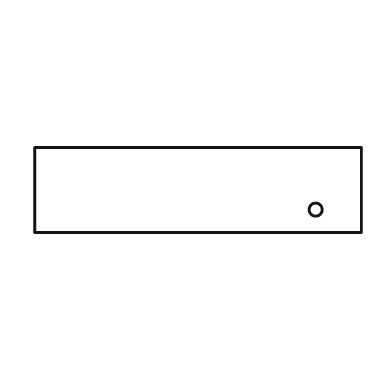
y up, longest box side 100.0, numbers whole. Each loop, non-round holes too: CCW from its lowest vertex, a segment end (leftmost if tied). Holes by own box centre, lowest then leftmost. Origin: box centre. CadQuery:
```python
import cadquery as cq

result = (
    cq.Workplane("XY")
    .moveTo(-50.0, -13.0)
    .lineTo(50.0, -13.0)
    .lineTo(50.0, 13.0)
    .lineTo(-50.0, 13.0)
    .close()
    .moveTo(36.0, -6.0)
    .circle(2.0)
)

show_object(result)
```